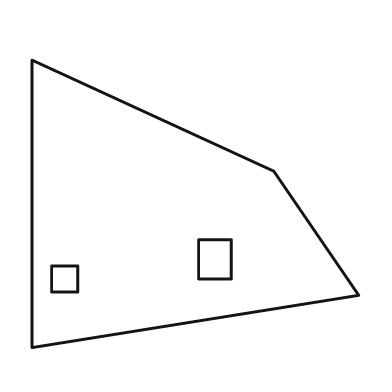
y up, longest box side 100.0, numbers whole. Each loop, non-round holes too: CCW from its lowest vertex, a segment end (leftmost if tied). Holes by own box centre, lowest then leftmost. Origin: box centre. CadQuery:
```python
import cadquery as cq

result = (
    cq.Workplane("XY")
    .moveTo(-50.0, -44.0)
    .lineTo(50.0, -28.0)
    .lineTo(24.0, 10.0)
    .lineTo(-50.0, 44.0)
    .close()
    .moveTo(-44.0, -27.0)
    .lineTo(-36.0, -27.0)
    .lineTo(-36.0, -19.0)
    .lineTo(-44.0, -19.0)
    .close()
    .moveTo(1.0, -23.0)
    .lineTo(11.0, -23.0)
    .lineTo(11.0, -11.0)
    .lineTo(1.0, -11.0)
    .close()
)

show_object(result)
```